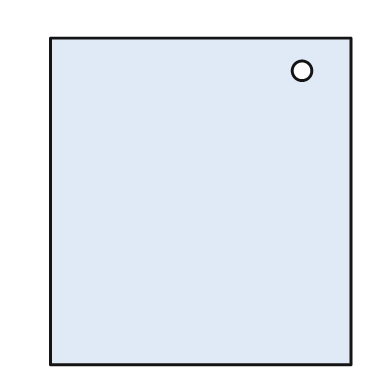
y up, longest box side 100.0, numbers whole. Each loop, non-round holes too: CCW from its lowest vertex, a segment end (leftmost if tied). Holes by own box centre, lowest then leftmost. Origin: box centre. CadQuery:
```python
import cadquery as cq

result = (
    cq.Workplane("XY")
    .moveTo(-46.0, -50.0)
    .lineTo(46.0, -50.0)
    .lineTo(46.0, 50.0)
    .lineTo(-46.0, 50.0)
    .close()
    .moveTo(31.0, 40.0)
    .circle(3.0)
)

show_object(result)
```